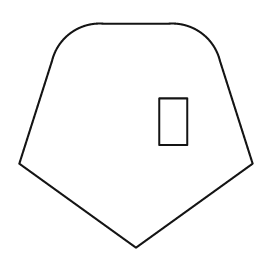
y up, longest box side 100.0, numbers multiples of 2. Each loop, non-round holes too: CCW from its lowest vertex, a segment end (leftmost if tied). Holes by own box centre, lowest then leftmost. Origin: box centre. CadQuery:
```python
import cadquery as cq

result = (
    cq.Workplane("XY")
    .moveTo(0.0, -48.0)
    .lineTo(50.0, -12.0)
    .lineTo(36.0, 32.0)
    .threePointArc((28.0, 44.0), (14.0, 48.0))
    .lineTo(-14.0, 48.0)
    .threePointArc((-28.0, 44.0), (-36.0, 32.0))
    .lineTo(-50.0, -12.0)
    .close()
    .moveTo(10.0, -4.0)
    .lineTo(22.0, -4.0)
    .lineTo(22.0, 16.0)
    .lineTo(10.0, 16.0)
    .close()
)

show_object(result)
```